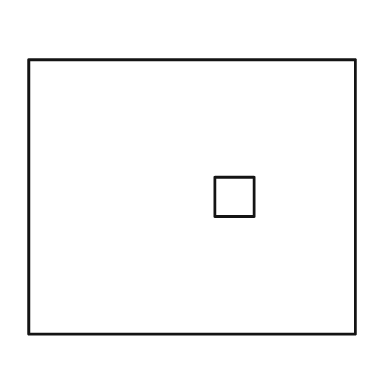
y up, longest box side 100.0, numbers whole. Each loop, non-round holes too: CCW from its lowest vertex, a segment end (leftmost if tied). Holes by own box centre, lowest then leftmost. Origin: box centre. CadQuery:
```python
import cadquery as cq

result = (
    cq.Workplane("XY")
    .moveTo(-50.0, -42.0)
    .lineTo(50.0, -42.0)
    .lineTo(50.0, 42.0)
    .lineTo(-50.0, 42.0)
    .close()
    .moveTo(7.0, -6.0)
    .lineTo(19.0, -6.0)
    .lineTo(19.0, 6.0)
    .lineTo(7.0, 6.0)
    .close()
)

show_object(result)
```